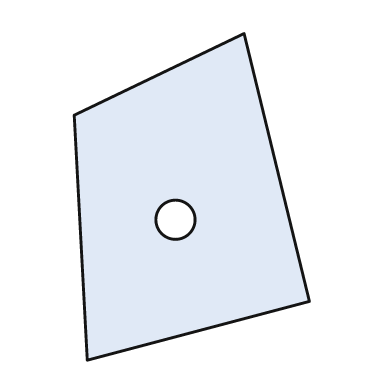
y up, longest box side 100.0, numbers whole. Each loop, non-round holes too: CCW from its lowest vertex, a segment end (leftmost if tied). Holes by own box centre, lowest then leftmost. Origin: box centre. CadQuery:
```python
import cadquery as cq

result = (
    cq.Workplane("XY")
    .moveTo(-32.0, -50.0)
    .lineTo(36.0, -32.0)
    .lineTo(16.0, 50.0)
    .lineTo(-36.0, 25.0)
    .close()
    .moveTo(-5.0, -7.0)
    .circle(6.0)
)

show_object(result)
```